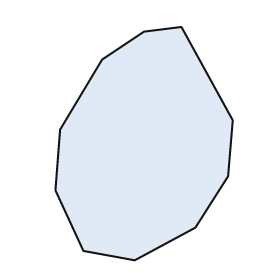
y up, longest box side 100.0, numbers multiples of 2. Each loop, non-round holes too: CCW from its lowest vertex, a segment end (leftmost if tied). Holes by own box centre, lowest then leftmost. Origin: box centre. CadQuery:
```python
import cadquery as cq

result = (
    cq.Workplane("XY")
    .moveTo(-4.0, -50.0)
    .lineTo(22.0, -36.0)
    .lineTo(36.0, -14.0)
    .lineTo(38.0, 10.0)
    .lineTo(16.0, 50.0)
    .lineTo(0.0, 48.0)
    .lineTo(-18.0, 36.0)
    .lineTo(-36.0, 6.0)
    .lineTo(-38.0, -20.0)
    .lineTo(-26.0, -46.0)
    .close()
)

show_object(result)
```